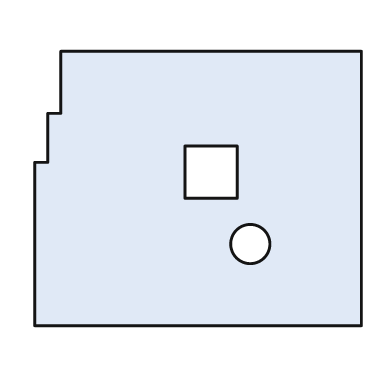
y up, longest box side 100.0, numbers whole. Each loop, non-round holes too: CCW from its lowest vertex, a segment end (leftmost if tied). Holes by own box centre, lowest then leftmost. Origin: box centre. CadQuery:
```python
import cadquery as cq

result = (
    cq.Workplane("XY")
    .moveTo(-50.0, -42.0)
    .lineTo(50.0, -42.0)
    .lineTo(50.0, 42.0)
    .lineTo(-42.0, 42.0)
    .lineTo(-42.0, 23.0)
    .lineTo(-46.0, 23.0)
    .lineTo(-46.0, 8.0)
    .lineTo(-50.0, 8.0)
    .close()
    .moveTo(16.0, -17.0)
    .circle(6.0)
    .moveTo(-4.0, -3.0)
    .lineTo(12.0, -3.0)
    .lineTo(12.0, 13.0)
    .lineTo(-4.0, 13.0)
    .close()
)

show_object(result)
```